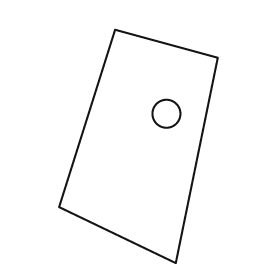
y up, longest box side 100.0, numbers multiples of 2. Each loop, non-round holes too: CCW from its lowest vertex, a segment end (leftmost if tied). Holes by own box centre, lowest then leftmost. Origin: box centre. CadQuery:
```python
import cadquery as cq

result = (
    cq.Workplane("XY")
    .moveTo(16.0, -50.0)
    .lineTo(34.0, 38.0)
    .lineTo(-10.0, 50.0)
    .lineTo(-34.0, -26.0)
    .close()
    .moveTo(12.0, 14.0)
    .circle(6.0)
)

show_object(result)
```